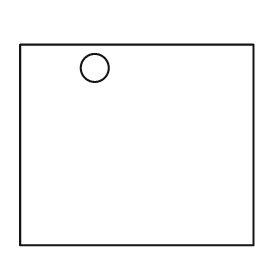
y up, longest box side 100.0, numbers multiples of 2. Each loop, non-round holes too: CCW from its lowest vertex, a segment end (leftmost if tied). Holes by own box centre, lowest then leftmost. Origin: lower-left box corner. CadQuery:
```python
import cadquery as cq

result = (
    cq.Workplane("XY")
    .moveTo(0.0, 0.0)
    .lineTo(100.0, 0.0)
    .lineTo(100.0, 86.0)
    .lineTo(0.0, 86.0)
    .close()
    .moveTo(32.0, 76.0)
    .circle(6.0)
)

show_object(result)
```